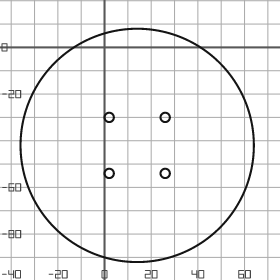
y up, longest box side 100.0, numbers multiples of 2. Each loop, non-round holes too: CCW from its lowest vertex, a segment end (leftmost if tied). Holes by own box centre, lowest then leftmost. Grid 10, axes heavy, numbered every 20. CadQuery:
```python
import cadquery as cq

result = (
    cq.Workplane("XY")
    .moveTo(14.0, -42.0)
    .circle(50.0)
    .moveTo(2.0, -54.0)
    .circle(2.0)
    .moveTo(26.0, -54.0)
    .circle(2.0)
    .moveTo(2.0, -30.0)
    .circle(2.0)
    .moveTo(26.0, -30.0)
    .circle(2.0)
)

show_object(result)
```